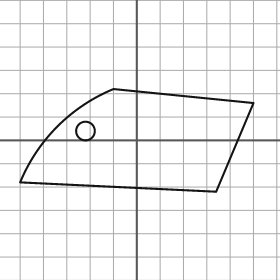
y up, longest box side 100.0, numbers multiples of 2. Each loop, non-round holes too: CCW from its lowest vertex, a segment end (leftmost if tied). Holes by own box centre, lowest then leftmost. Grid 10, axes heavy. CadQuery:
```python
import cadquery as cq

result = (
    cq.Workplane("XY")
    .moveTo(34.0, -22.0)
    .lineTo(50.0, 16.0)
    .lineTo(-10.0, 22.0)
    .threePointArc((-34.0, 6.0), (-50.0, -18.0))
    .close()
    .moveTo(-22.0, 4.0)
    .circle(4.0)
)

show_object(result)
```